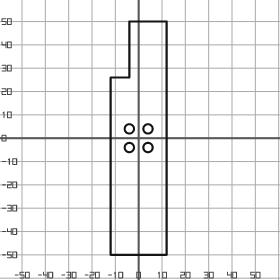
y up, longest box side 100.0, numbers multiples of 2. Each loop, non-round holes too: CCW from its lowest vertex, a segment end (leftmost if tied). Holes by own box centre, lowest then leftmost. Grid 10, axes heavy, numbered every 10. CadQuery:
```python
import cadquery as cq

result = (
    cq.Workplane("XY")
    .moveTo(-12.0, -50.0)
    .lineTo(12.0, -50.0)
    .lineTo(12.0, 50.0)
    .lineTo(-4.0, 50.0)
    .lineTo(-4.0, 26.0)
    .lineTo(-12.0, 26.0)
    .close()
    .moveTo(-4.0, -4.0)
    .circle(2.0)
    .moveTo(4.0, -4.0)
    .circle(2.0)
    .moveTo(-4.0, 4.0)
    .circle(2.0)
    .moveTo(4.0, 4.0)
    .circle(2.0)
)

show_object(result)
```